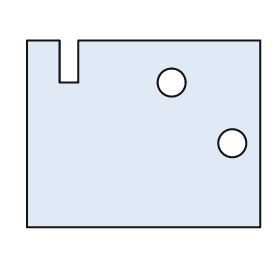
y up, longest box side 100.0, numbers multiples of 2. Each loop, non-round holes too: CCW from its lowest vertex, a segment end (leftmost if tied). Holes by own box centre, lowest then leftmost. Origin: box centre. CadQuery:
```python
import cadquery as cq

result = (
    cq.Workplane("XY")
    .moveTo(-50.0, -40.0)
    .lineTo(50.0, -40.0)
    .lineTo(50.0, 40.0)
    .lineTo(-28.0, 40.0)
    .lineTo(-28.0, 22.0)
    .lineTo(-36.0, 22.0)
    .lineTo(-36.0, 40.0)
    .lineTo(-50.0, 40.0)
    .close()
    .moveTo(38.0, -4.0)
    .circle(6.0)
    .moveTo(12.0, 22.0)
    .circle(6.0)
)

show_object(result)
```